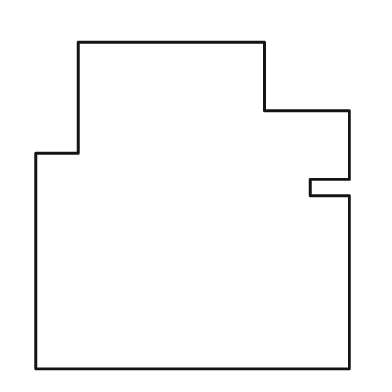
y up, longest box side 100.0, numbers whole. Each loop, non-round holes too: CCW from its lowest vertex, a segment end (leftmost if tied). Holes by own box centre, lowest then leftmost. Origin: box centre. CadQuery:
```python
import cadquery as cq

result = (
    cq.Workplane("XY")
    .moveTo(-48.0, -50.0)
    .lineTo(48.0, -50.0)
    .lineTo(48.0, 3.0)
    .lineTo(36.0, 3.0)
    .lineTo(36.0, 8.0)
    .lineTo(48.0, 8.0)
    .lineTo(48.0, 29.0)
    .lineTo(22.0, 29.0)
    .lineTo(22.0, 50.0)
    .lineTo(-35.0, 50.0)
    .lineTo(-35.0, 16.0)
    .lineTo(-48.0, 16.0)
    .close()
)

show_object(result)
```